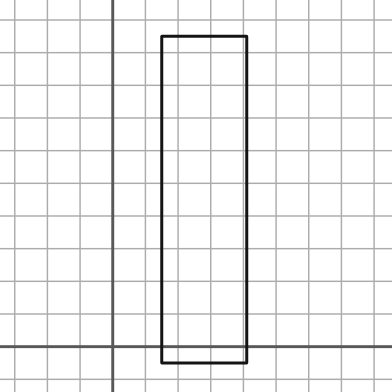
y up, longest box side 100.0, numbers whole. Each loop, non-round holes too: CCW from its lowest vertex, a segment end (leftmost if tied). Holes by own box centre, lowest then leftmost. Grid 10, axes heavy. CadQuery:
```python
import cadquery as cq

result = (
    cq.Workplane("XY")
    .moveTo(15.0, -5.0)
    .lineTo(41.0, -5.0)
    .lineTo(41.0, 95.0)
    .lineTo(15.0, 95.0)
    .close()
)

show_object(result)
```